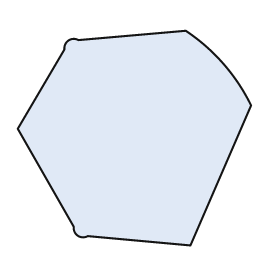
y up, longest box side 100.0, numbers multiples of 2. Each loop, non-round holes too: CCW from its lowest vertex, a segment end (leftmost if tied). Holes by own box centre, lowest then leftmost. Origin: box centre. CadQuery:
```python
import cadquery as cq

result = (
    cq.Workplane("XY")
    .moveTo(24.0, -46.0)
    .lineTo(50.0, 14.0)
    .threePointArc((38.0, 32.0), (22.0, 46.0))
    .lineTo(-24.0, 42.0)
    .threePointArc((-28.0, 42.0), (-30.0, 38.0))
    .lineTo(-50.0, 4.0)
    .lineTo(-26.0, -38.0)
    .threePointArc((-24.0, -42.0), (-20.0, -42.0))
    .close()
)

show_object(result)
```